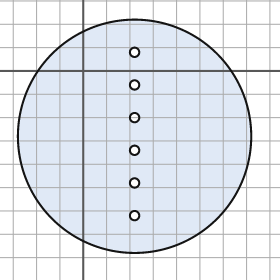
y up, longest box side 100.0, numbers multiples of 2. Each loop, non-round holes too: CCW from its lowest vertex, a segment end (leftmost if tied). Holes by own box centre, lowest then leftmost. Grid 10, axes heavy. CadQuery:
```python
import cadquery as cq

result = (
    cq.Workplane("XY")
    .moveTo(22.0, -28.0)
    .circle(50.0)
    .moveTo(22.0, -62.0)
    .circle(2.0)
    .moveTo(22.0, -48.0)
    .circle(2.0)
    .moveTo(22.0, -34.0)
    .circle(2.0)
    .moveTo(22.0, -20.0)
    .circle(2.0)
    .moveTo(22.0, -6.0)
    .circle(2.0)
    .moveTo(22.0, 8.0)
    .circle(2.0)
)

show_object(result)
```